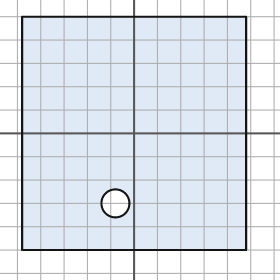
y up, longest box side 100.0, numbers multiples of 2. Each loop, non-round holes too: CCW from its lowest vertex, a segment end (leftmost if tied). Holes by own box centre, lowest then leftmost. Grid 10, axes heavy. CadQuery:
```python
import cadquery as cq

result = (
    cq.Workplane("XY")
    .moveTo(-48.0, -50.0)
    .lineTo(48.0, -50.0)
    .lineTo(48.0, 50.0)
    .lineTo(-48.0, 50.0)
    .close()
    .moveTo(-8.0, -30.0)
    .circle(6.0)
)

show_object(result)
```